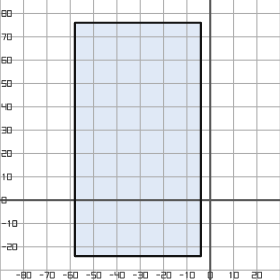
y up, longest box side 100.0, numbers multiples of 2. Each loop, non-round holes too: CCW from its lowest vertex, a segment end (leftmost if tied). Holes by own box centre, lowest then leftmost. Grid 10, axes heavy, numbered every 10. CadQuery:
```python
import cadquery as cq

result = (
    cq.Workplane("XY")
    .moveTo(-58.0, -24.0)
    .lineTo(-4.0, -24.0)
    .lineTo(-4.0, 76.0)
    .lineTo(-58.0, 76.0)
    .close()
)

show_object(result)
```